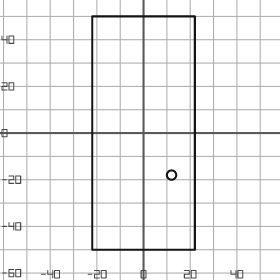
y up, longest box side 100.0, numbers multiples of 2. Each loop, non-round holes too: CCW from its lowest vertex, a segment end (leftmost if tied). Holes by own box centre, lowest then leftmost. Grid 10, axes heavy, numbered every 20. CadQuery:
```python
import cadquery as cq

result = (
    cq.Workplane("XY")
    .moveTo(-22.0, -50.0)
    .lineTo(22.0, -50.0)
    .lineTo(22.0, 50.0)
    .lineTo(-22.0, 50.0)
    .close()
    .moveTo(12.0, -18.0)
    .circle(2.0)
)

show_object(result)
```